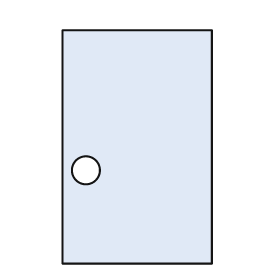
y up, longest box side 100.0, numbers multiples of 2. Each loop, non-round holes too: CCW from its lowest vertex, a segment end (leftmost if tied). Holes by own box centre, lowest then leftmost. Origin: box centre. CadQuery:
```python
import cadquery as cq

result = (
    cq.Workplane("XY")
    .moveTo(-32.0, -50.0)
    .lineTo(32.0, -50.0)
    .lineTo(32.0, 50.0)
    .lineTo(-32.0, 50.0)
    .close()
    .moveTo(-22.0, -10.0)
    .circle(6.0)
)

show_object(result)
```